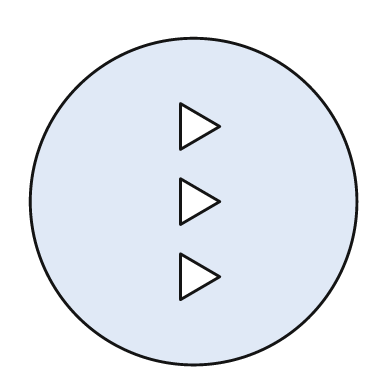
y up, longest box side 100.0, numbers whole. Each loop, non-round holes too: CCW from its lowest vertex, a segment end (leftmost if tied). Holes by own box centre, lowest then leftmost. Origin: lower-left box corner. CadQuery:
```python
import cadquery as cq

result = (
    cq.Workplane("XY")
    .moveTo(50.0, 50.0)
    .circle(50.0)
    .moveTo(46.0, 20.0)
    .lineTo(58.0, 27.0)
    .lineTo(46.0, 34.0)
    .close()
    .moveTo(46.0, 43.0)
    .lineTo(58.0, 50.0)
    .lineTo(46.0, 57.0)
    .close()
    .moveTo(46.0, 66.0)
    .lineTo(58.0, 73.0)
    .lineTo(46.0, 80.0)
    .close()
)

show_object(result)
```